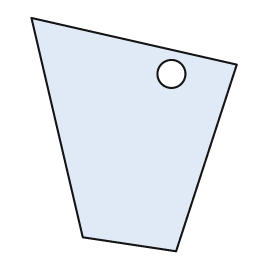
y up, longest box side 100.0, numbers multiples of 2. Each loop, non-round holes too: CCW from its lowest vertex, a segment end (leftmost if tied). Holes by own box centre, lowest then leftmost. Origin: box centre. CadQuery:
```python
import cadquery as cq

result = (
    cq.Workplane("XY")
    .moveTo(18.0, -50.0)
    .lineTo(44.0, 30.0)
    .lineTo(-44.0, 50.0)
    .lineTo(-22.0, -44.0)
    .close()
    .moveTo(16.0, 26.0)
    .circle(6.0)
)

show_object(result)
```